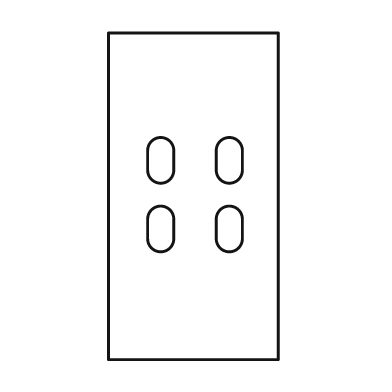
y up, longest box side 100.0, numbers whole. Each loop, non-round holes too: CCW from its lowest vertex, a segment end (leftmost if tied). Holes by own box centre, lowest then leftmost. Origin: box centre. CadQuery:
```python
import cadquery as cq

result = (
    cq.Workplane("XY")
    .moveTo(-26.0, -50.0)
    .lineTo(26.0, -50.0)
    .lineTo(26.0, 50.0)
    .lineTo(-26.0, 50.0)
    .close()
    .moveTo(-14.0, -13.0)
    .threePointArc((-10.0, -17.0), (-6.0, -13.0))
    .lineTo(-6.0, -7.0)
    .threePointArc((-10.0, -3.0), (-14.0, -7.0))
    .close()
    .moveTo(7.0, -13.0)
    .threePointArc((11.0, -17.0), (15.0, -13.0))
    .lineTo(15.0, -7.0)
    .threePointArc((11.0, -3.0), (7.0, -7.0))
    .close()
    .moveTo(-14.0, 8.0)
    .threePointArc((-10.0, 4.0), (-6.0, 8.0))
    .lineTo(-6.0, 14.0)
    .threePointArc((-10.0, 18.0), (-14.0, 14.0))
    .close()
    .moveTo(7.0, 8.0)
    .threePointArc((11.0, 4.0), (15.0, 8.0))
    .lineTo(15.0, 14.0)
    .threePointArc((11.0, 18.0), (7.0, 14.0))
    .close()
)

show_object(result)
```